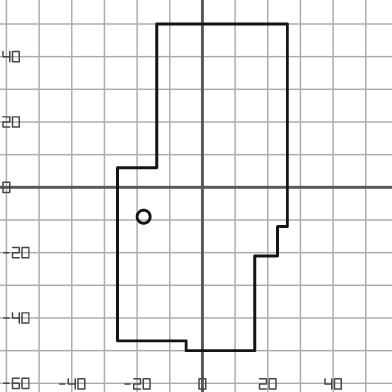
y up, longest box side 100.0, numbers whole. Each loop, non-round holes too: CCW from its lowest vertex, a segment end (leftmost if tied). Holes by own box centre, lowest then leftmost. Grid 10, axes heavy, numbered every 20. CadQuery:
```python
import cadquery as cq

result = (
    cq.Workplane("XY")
    .moveTo(-5.0, -50.0)
    .lineTo(16.0, -50.0)
    .lineTo(16.0, -21.0)
    .lineTo(23.0, -21.0)
    .lineTo(23.0, -12.0)
    .lineTo(26.0, -12.0)
    .lineTo(26.0, 50.0)
    .lineTo(-14.0, 50.0)
    .lineTo(-14.0, 6.0)
    .lineTo(-26.0, 6.0)
    .lineTo(-26.0, -47.0)
    .lineTo(-5.0, -47.0)
    .close()
    .moveTo(-18.0, -9.0)
    .circle(2.0)
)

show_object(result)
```